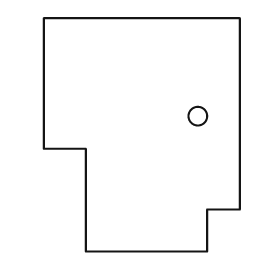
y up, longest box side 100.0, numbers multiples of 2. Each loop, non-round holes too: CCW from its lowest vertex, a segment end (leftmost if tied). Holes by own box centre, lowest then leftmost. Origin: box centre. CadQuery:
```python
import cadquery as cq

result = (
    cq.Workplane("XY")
    .moveTo(-24.0, -50.0)
    .lineTo(28.0, -50.0)
    .lineTo(28.0, -32.0)
    .lineTo(42.0, -32.0)
    .lineTo(42.0, 50.0)
    .lineTo(-42.0, 50.0)
    .lineTo(-42.0, -6.0)
    .lineTo(-24.0, -6.0)
    .close()
    .moveTo(24.0, 8.0)
    .circle(4.0)
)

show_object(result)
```